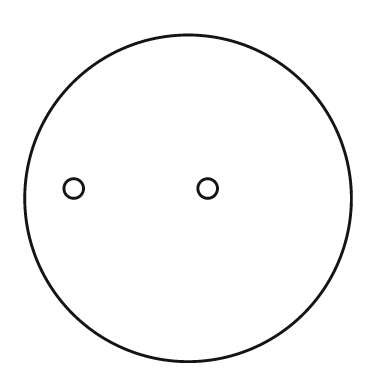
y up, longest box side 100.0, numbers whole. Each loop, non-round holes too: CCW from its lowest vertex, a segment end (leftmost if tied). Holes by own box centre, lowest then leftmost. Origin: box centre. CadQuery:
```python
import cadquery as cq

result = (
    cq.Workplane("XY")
    .moveTo(0.0, 0.0)
    .circle(50.0)
    .moveTo(-35.0, 3.0)
    .circle(3.0)
    .moveTo(6.0, 3.0)
    .circle(3.0)
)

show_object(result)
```